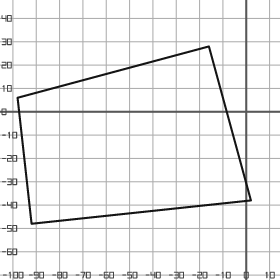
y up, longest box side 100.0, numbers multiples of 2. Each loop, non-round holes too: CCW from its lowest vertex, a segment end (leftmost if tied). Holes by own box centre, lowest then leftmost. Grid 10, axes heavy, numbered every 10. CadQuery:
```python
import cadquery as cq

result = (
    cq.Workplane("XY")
    .moveTo(-92.0, -48.0)
    .lineTo(2.0, -38.0)
    .lineTo(-16.0, 28.0)
    .lineTo(-98.0, 6.0)
    .close()
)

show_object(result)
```